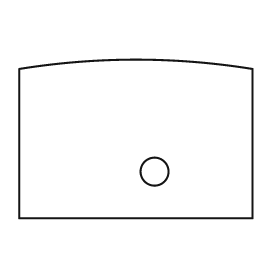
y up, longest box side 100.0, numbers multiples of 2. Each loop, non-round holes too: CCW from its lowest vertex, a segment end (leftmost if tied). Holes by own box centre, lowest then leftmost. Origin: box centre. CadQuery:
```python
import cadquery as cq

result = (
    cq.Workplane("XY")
    .moveTo(-50.0, -34.0)
    .lineTo(50.0, -34.0)
    .lineTo(50.0, 30.0)
    .threePointArc((0.0, 34.0), (-50.0, 30.0))
    .close()
    .moveTo(8.0, -14.0)
    .circle(6.0)
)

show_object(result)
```